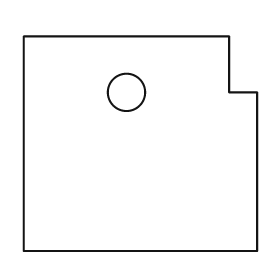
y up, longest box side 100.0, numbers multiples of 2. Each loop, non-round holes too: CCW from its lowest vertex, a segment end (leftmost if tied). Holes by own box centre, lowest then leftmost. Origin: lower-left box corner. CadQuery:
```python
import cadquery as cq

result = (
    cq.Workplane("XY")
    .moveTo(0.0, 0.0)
    .lineTo(100.0, 0.0)
    .lineTo(100.0, 68.0)
    .lineTo(88.0, 68.0)
    .lineTo(88.0, 92.0)
    .lineTo(0.0, 92.0)
    .close()
    .moveTo(44.0, 68.0)
    .circle(8.0)
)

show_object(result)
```